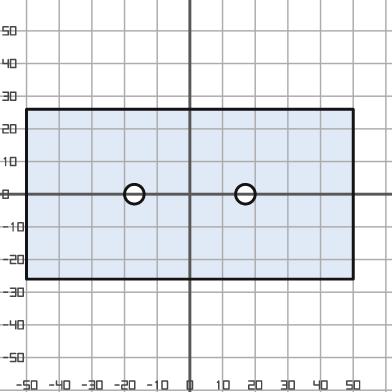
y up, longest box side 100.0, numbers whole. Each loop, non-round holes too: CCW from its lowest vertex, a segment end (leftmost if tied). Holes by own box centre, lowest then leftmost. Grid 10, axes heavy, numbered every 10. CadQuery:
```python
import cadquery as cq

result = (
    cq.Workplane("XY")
    .moveTo(-50.0, -26.0)
    .lineTo(50.0, -26.0)
    .lineTo(50.0, 26.0)
    .lineTo(-50.0, 26.0)
    .close()
    .moveTo(-17.0, 0.0)
    .circle(3.0)
    .moveTo(17.0, 0.0)
    .circle(3.0)
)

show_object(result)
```